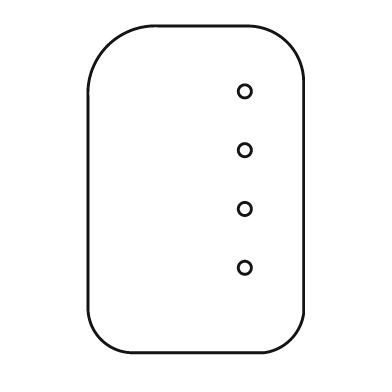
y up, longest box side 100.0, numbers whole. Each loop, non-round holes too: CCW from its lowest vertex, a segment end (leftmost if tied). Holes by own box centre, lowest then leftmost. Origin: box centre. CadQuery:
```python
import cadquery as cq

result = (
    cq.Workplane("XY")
    .moveTo(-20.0, -50.0)
    .lineTo(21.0, -50.0)
    .threePointArc((29.0, -46.0), (33.0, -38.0))
    .lineTo(33.0, 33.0)
    .threePointArc((28.0, 45.0), (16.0, 50.0))
    .lineTo(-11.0, 50.0)
    .threePointArc((-27.0, 44.0), (-33.0, 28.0))
    .lineTo(-33.0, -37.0)
    .threePointArc((-29.0, -46.0), (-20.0, -50.0))
    .close()
    .moveTo(15.0, -24.0)
    .circle(2.0)
    .moveTo(15.0, -6.0)
    .circle(2.0)
    .moveTo(15.0, 12.0)
    .circle(2.0)
    .moveTo(15.0, 30.0)
    .circle(2.0)
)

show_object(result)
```